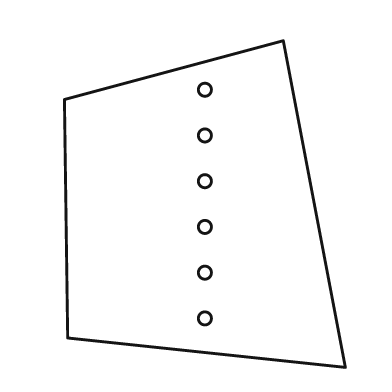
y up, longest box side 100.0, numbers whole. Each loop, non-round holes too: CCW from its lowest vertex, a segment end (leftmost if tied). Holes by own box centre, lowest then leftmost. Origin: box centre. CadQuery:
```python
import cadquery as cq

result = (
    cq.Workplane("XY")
    .moveTo(43.0, -50.0)
    .lineTo(24.0, 50.0)
    .lineTo(-43.0, 32.0)
    .lineTo(-42.0, -41.0)
    .close()
    .moveTo(0.0, -35.0)
    .circle(2.0)
    .moveTo(0.0, -21.0)
    .circle(2.0)
    .moveTo(0.0, -7.0)
    .circle(2.0)
    .moveTo(0.0, 7.0)
    .circle(2.0)
    .moveTo(0.0, 21.0)
    .circle(2.0)
    .moveTo(0.0, 35.0)
    .circle(2.0)
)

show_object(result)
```